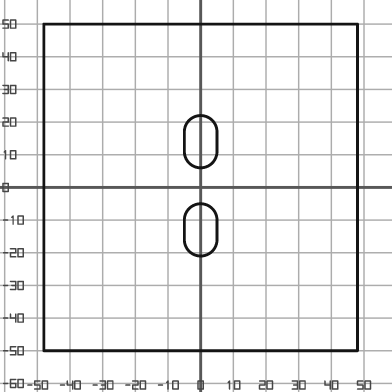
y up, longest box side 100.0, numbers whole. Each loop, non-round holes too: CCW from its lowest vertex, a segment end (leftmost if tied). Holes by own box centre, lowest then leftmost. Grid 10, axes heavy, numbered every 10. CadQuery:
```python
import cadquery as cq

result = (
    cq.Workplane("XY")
    .moveTo(-48.0, -50.0)
    .lineTo(48.0, -50.0)
    .lineTo(48.0, 50.0)
    .lineTo(-48.0, 50.0)
    .close()
    .moveTo(-5.0, -16.0)
    .threePointArc((0.0, -21.0), (5.0, -16.0))
    .lineTo(5.0, -10.0)
    .threePointArc((0.0, -5.0), (-5.0, -10.0))
    .close()
    .moveTo(-5.0, 11.0)
    .threePointArc((0.0, 6.0), (5.0, 11.0))
    .lineTo(5.0, 17.0)
    .threePointArc((0.0, 22.0), (-5.0, 17.0))
    .close()
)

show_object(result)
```